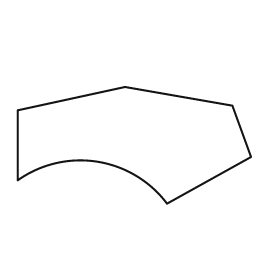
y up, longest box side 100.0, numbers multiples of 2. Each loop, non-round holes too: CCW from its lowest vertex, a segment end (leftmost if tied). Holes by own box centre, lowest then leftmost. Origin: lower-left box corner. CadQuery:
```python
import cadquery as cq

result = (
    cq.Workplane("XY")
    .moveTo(64.0, 0.0)
    .lineTo(100.0, 20.0)
    .lineTo(92.0, 42.0)
    .lineTo(46.0, 50.0)
    .lineTo(0.0, 40.0)
    .lineTo(0.0, 10.0)
    .threePointArc((34.0, 18.0), (64.0, 0.0))
    .close()
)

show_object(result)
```